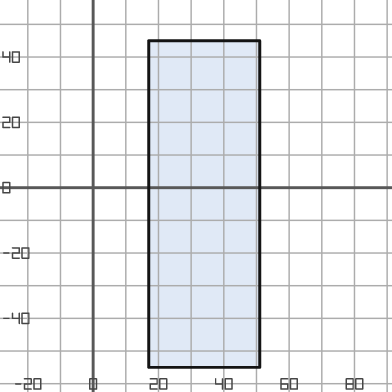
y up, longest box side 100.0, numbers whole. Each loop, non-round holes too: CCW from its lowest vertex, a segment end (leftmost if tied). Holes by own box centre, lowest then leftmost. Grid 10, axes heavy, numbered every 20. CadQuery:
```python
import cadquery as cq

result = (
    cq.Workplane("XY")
    .moveTo(17.0, -55.0)
    .lineTo(51.0, -55.0)
    .lineTo(51.0, 45.0)
    .lineTo(17.0, 45.0)
    .close()
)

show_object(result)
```